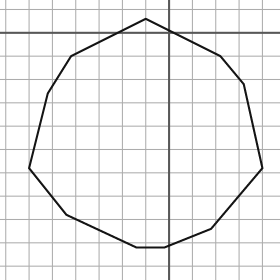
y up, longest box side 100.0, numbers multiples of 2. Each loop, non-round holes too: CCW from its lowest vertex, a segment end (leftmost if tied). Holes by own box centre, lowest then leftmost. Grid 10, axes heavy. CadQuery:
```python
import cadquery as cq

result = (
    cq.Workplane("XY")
    .moveTo(-14.0, -92.0)
    .lineTo(-2.0, -92.0)
    .lineTo(18.0, -84.0)
    .lineTo(40.0, -58.0)
    .lineTo(32.0, -22.0)
    .lineTo(22.0, -10.0)
    .lineTo(-10.0, 6.0)
    .lineTo(-42.0, -10.0)
    .lineTo(-52.0, -26.0)
    .lineTo(-60.0, -58.0)
    .lineTo(-44.0, -78.0)
    .close()
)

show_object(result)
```